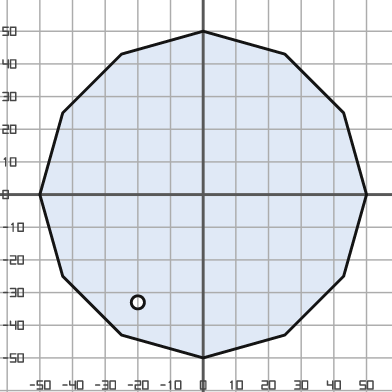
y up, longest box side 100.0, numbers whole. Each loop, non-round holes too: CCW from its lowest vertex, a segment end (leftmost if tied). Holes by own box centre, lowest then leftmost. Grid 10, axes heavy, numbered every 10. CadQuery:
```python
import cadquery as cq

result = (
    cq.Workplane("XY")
    .moveTo(0.0, -50.0)
    .lineTo(25.0, -43.0)
    .lineTo(43.0, -25.0)
    .lineTo(50.0, 0.0)
    .lineTo(43.0, 25.0)
    .lineTo(25.0, 43.0)
    .lineTo(0.0, 50.0)
    .lineTo(-25.0, 43.0)
    .lineTo(-43.0, 25.0)
    .lineTo(-50.0, 0.0)
    .lineTo(-43.0, -25.0)
    .lineTo(-25.0, -43.0)
    .close()
    .moveTo(-20.0, -33.0)
    .circle(2.0)
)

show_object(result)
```